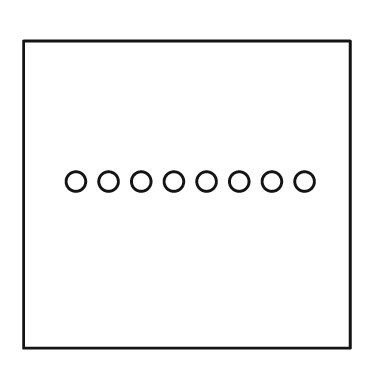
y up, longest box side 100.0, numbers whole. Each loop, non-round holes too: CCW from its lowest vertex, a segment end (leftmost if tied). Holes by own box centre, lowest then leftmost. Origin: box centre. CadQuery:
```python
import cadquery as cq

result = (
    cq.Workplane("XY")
    .moveTo(-50.0, -47.0)
    .lineTo(50.0, -47.0)
    .lineTo(50.0, 47.0)
    .lineTo(-50.0, 47.0)
    .close()
    .moveTo(-34.0, 4.0)
    .circle(3.0)
    .moveTo(-24.0, 4.0)
    .circle(3.0)
    .moveTo(-14.0, 4.0)
    .circle(3.0)
    .moveTo(-4.0, 4.0)
    .circle(3.0)
    .moveTo(6.0, 4.0)
    .circle(3.0)
    .moveTo(16.0, 4.0)
    .circle(3.0)
    .moveTo(26.0, 4.0)
    .circle(3.0)
    .moveTo(36.0, 4.0)
    .circle(3.0)
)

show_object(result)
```